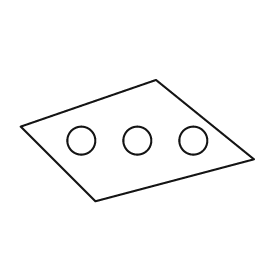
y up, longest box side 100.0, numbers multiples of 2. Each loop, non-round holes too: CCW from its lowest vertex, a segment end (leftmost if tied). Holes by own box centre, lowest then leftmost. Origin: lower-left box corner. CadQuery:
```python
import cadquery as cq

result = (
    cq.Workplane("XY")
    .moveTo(32.0, 0.0)
    .lineTo(100.0, 18.0)
    .lineTo(58.0, 52.0)
    .lineTo(0.0, 32.0)
    .close()
    .moveTo(26.0, 26.0)
    .circle(6.0)
    .moveTo(50.0, 26.0)
    .circle(6.0)
    .moveTo(74.0, 26.0)
    .circle(6.0)
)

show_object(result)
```